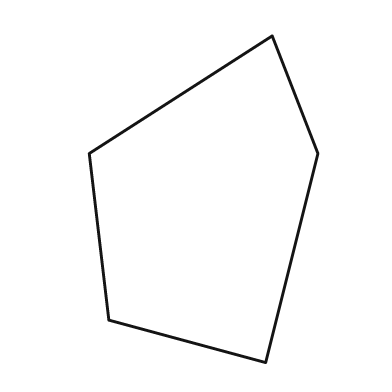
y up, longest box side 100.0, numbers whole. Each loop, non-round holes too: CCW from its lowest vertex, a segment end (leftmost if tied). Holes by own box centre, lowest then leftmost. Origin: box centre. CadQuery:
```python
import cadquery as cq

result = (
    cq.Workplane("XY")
    .moveTo(19.0, -50.0)
    .lineTo(35.0, 14.0)
    .lineTo(21.0, 50.0)
    .lineTo(-35.0, 14.0)
    .lineTo(-29.0, -37.0)
    .close()
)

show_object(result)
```